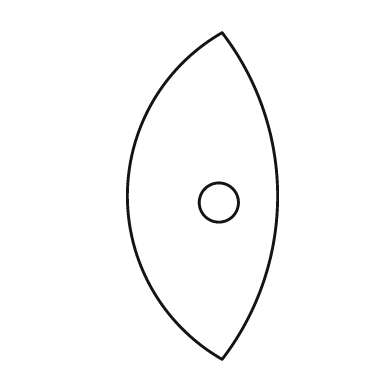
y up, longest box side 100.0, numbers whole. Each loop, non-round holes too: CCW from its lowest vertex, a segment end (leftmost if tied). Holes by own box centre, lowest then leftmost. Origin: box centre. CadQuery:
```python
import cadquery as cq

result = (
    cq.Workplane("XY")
    .moveTo(6.0, -50.0)
    .threePointArc((23.0, 0.0), (6.0, 50.0))
    .threePointArc((-23.0, 0.0), (6.0, -50.0))
    .close()
    .moveTo(5.0, -2.0)
    .circle(6.0)
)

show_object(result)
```